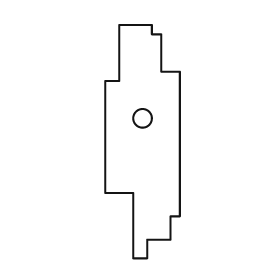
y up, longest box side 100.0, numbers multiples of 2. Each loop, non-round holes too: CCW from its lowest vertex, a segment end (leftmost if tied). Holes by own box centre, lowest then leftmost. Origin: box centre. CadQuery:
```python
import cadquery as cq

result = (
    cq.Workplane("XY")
    .moveTo(-4.0, -50.0)
    .lineTo(2.0, -50.0)
    .lineTo(2.0, -42.0)
    .lineTo(12.0, -42.0)
    .lineTo(12.0, -32.0)
    .lineTo(16.0, -32.0)
    .lineTo(16.0, 30.0)
    .lineTo(8.0, 30.0)
    .lineTo(8.0, 46.0)
    .lineTo(4.0, 46.0)
    .lineTo(4.0, 50.0)
    .lineTo(-10.0, 50.0)
    .lineTo(-10.0, 26.0)
    .lineTo(-16.0, 26.0)
    .lineTo(-16.0, -22.0)
    .lineTo(-4.0, -22.0)
    .close()
    .moveTo(0.0, 10.0)
    .circle(4.0)
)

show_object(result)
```